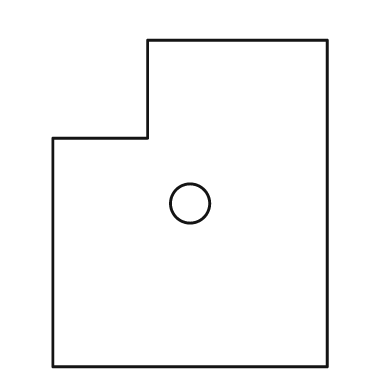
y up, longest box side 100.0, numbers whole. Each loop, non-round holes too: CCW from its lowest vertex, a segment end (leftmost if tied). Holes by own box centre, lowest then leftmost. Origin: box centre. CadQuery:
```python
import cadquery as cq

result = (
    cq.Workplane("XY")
    .moveTo(-42.0, -50.0)
    .lineTo(42.0, -50.0)
    .lineTo(42.0, 50.0)
    .lineTo(-13.0, 50.0)
    .lineTo(-13.0, 20.0)
    .lineTo(-42.0, 20.0)
    .close()
    .moveTo(0.0, 0.0)
    .circle(6.0)
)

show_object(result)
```